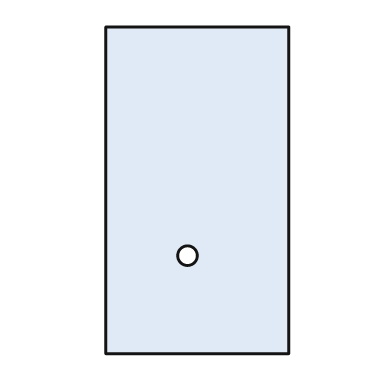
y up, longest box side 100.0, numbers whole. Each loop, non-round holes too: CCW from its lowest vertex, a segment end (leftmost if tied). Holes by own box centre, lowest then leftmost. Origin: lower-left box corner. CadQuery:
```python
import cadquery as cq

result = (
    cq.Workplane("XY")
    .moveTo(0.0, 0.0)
    .lineTo(56.0, 0.0)
    .lineTo(56.0, 100.0)
    .lineTo(0.0, 100.0)
    .close()
    .moveTo(25.0, 30.0)
    .circle(3.0)
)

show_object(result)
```